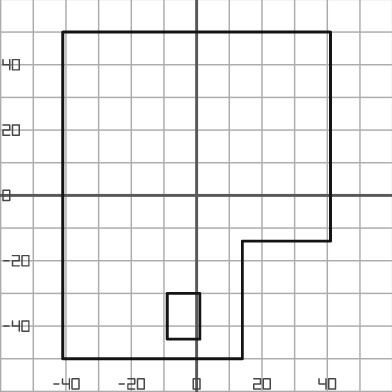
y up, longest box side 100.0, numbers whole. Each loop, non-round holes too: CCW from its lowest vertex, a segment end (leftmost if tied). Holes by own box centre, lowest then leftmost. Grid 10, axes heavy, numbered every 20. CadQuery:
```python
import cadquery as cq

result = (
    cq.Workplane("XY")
    .moveTo(-41.0, -50.0)
    .lineTo(14.0, -50.0)
    .lineTo(14.0, -14.0)
    .lineTo(41.0, -14.0)
    .lineTo(41.0, 50.0)
    .lineTo(-41.0, 50.0)
    .close()
    .moveTo(-9.0, -44.0)
    .lineTo(1.0, -44.0)
    .lineTo(1.0, -30.0)
    .lineTo(-9.0, -30.0)
    .close()
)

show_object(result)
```